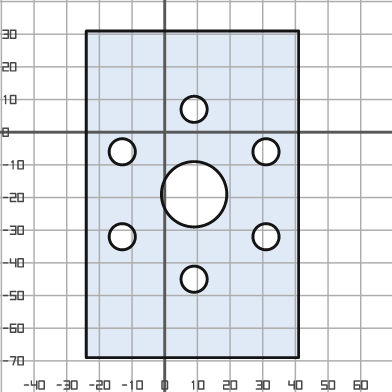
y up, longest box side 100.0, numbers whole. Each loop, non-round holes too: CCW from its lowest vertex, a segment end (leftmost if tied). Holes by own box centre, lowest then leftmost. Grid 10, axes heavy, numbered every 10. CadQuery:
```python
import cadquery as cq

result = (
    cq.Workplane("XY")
    .moveTo(-24.0, -69.0)
    .lineTo(41.0, -69.0)
    .lineTo(41.0, 31.0)
    .lineTo(-24.0, 31.0)
    .close()
    .moveTo(9.0, -45.0)
    .circle(4.0)
    .moveTo(-13.0, -32.0)
    .circle(4.0)
    .moveTo(31.0, -32.0)
    .circle(4.0)
    .moveTo(9.0, -19.0)
    .circle(10.0)
    .moveTo(-13.0, -6.0)
    .circle(4.0)
    .moveTo(31.0, -6.0)
    .circle(4.0)
    .moveTo(9.0, 7.0)
    .circle(4.0)
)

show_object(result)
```